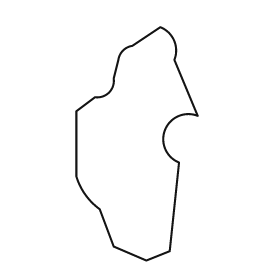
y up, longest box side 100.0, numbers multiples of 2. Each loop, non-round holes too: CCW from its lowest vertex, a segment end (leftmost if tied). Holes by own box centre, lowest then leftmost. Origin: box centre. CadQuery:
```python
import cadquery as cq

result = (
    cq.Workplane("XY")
    .moveTo(4.0, -50.0)
    .lineTo(14.0, -46.0)
    .lineTo(18.0, -8.0)
    .threePointArc((12.0, 6.0), (26.0, 12.0))
    .lineTo(16.0, 36.0)
    .threePointArc((16.0, 44.0), (10.0, 50.0))
    .lineTo(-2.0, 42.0)
    .threePointArc((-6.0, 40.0), (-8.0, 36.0))
    .lineTo(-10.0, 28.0)
    .threePointArc((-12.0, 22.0), (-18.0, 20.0))
    .lineTo(-26.0, 14.0)
    .lineTo(-26.0, -14.0)
    .threePointArc((-22.0, -22.0), (-16.0, -28.0))
    .lineTo(-10.0, -44.0)
    .close()
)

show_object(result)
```